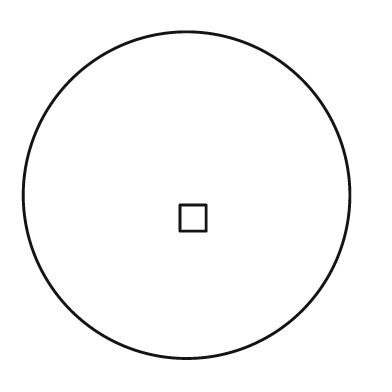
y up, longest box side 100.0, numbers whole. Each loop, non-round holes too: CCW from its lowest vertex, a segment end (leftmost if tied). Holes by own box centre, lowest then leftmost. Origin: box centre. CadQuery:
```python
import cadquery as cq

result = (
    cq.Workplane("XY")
    .moveTo(0.0, 0.0)
    .circle(50.0)
    .moveTo(-2.0, -11.0)
    .lineTo(6.0, -11.0)
    .lineTo(6.0, -3.0)
    .lineTo(-2.0, -3.0)
    .close()
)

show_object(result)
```